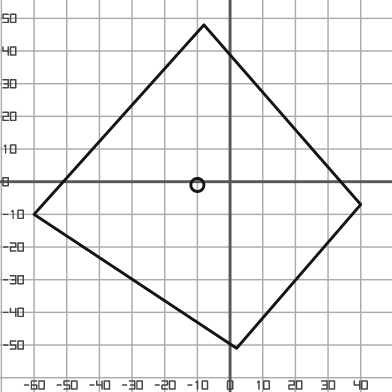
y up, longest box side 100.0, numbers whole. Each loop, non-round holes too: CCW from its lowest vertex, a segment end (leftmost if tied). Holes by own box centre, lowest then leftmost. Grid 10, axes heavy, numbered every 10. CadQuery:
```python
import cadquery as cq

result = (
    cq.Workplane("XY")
    .moveTo(2.0, -51.0)
    .lineTo(40.0, -7.0)
    .lineTo(-8.0, 48.0)
    .lineTo(-60.0, -10.0)
    .close()
    .moveTo(-10.0, -1.0)
    .circle(2.0)
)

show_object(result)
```